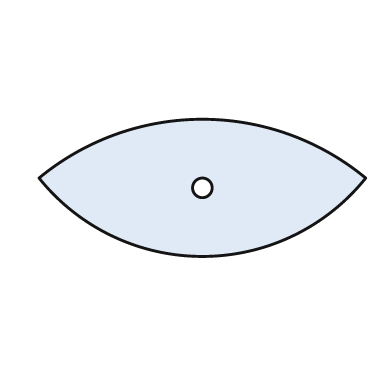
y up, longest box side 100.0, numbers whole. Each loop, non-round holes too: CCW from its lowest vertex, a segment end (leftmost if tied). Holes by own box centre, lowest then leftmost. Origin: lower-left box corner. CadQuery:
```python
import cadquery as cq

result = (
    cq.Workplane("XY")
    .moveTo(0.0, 24.0)
    .threePointArc((50.0, 0.0), (100.0, 24.0))
    .threePointArc((50.0, 42.0), (0.0, 24.0))
    .close()
    .moveTo(50.0, 21.0)
    .circle(3.0)
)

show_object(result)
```